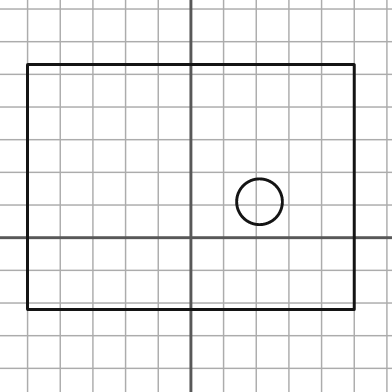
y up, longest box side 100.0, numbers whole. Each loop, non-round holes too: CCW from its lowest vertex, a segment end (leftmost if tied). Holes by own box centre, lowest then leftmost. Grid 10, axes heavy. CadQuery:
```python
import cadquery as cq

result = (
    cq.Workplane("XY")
    .moveTo(-50.0, -22.0)
    .lineTo(50.0, -22.0)
    .lineTo(50.0, 53.0)
    .lineTo(-50.0, 53.0)
    .close()
    .moveTo(21.0, 11.0)
    .circle(7.0)
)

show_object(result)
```